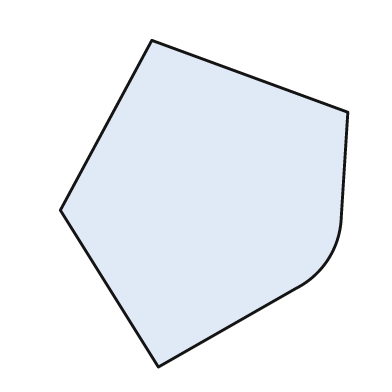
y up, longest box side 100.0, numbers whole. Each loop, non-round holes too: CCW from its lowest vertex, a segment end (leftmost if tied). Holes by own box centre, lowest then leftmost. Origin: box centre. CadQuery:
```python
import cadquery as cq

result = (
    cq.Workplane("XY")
    .moveTo(-14.0, -50.0)
    .lineTo(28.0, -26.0)
    .threePointArc((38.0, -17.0), (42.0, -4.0))
    .lineTo(44.0, 28.0)
    .lineTo(-16.0, 50.0)
    .lineTo(-44.0, -2.0)
    .close()
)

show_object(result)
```